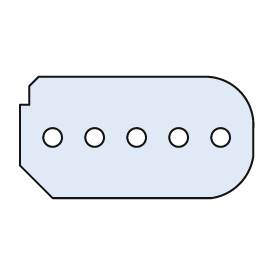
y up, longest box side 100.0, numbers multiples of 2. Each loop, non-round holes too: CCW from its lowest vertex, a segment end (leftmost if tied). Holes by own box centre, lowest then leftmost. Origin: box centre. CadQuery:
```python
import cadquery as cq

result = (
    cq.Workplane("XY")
    .moveTo(-36.0, -26.0)
    .lineTo(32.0, -26.0)
    .threePointArc((44.0, -20.0), (50.0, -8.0))
    .lineTo(50.0, 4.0)
    .threePointArc((44.0, 20.0), (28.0, 26.0))
    .lineTo(-42.0, 26.0)
    .lineTo(-46.0, 22.0)
    .lineTo(-46.0, 14.0)
    .lineTo(-50.0, 14.0)
    .lineTo(-50.0, -12.0)
    .close()
    .moveTo(-36.0, 0.0)
    .circle(4.0)
    .moveTo(-18.0, 0.0)
    .circle(4.0)
    .moveTo(0.0, 0.0)
    .circle(4.0)
    .moveTo(18.0, 0.0)
    .circle(4.0)
    .moveTo(36.0, 0.0)
    .circle(4.0)
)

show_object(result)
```